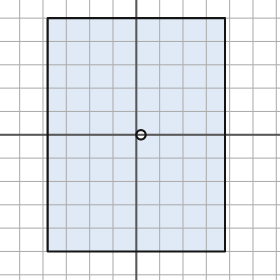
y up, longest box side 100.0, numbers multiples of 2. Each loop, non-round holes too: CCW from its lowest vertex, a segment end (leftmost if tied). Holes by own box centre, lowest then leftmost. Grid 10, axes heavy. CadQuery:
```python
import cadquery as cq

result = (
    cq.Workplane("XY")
    .moveTo(-38.0, -50.0)
    .lineTo(38.0, -50.0)
    .lineTo(38.0, 50.0)
    .lineTo(-38.0, 50.0)
    .close()
    .moveTo(2.0, 0.0)
    .circle(2.0)
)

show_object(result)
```